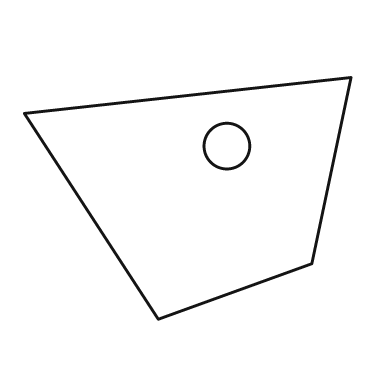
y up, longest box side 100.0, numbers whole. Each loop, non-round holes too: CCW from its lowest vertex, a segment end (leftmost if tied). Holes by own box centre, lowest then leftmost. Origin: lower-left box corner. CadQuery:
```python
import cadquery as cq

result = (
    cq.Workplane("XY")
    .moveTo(41.0, 0.0)
    .lineTo(88.0, 17.0)
    .lineTo(100.0, 74.0)
    .lineTo(0.0, 63.0)
    .close()
    .moveTo(62.0, 53.0)
    .circle(7.0)
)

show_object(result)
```